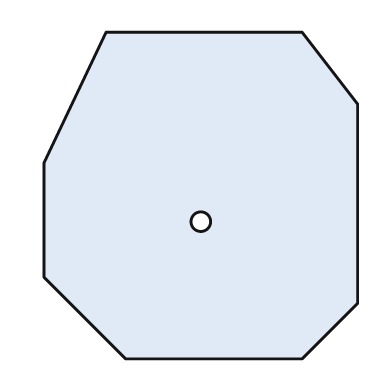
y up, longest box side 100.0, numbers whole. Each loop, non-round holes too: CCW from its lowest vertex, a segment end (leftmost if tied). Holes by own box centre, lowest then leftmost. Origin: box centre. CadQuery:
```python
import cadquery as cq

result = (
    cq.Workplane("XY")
    .moveTo(-23.0, -50.0)
    .lineTo(31.0, -50.0)
    .lineTo(48.0, -33.0)
    .lineTo(48.0, 28.0)
    .lineTo(31.0, 50.0)
    .lineTo(-29.0, 50.0)
    .lineTo(-48.0, 10.0)
    .lineTo(-48.0, -25.0)
    .close()
    .moveTo(0.0, -8.0)
    .circle(3.0)
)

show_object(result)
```